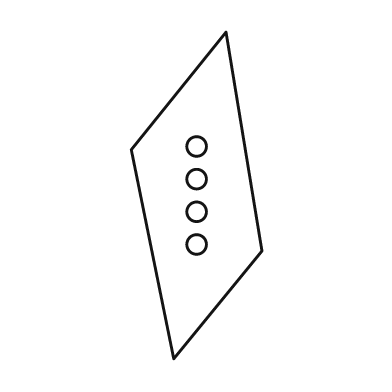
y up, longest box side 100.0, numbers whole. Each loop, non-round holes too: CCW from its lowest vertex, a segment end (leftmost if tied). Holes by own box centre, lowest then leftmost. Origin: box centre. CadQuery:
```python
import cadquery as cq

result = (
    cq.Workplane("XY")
    .moveTo(-7.0, -50.0)
    .lineTo(20.0, -17.0)
    .lineTo(9.0, 50.0)
    .lineTo(-20.0, 14.0)
    .close()
    .moveTo(0.0, -15.0)
    .circle(3.0)
    .moveTo(0.0, -5.0)
    .circle(3.0)
    .moveTo(0.0, 5.0)
    .circle(3.0)
    .moveTo(0.0, 15.0)
    .circle(3.0)
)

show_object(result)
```